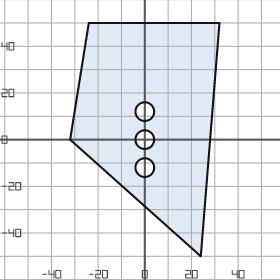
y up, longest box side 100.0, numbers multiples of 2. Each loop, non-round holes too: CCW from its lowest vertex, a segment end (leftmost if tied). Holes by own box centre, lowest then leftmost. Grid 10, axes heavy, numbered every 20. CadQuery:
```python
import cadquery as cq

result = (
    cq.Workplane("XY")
    .moveTo(24.0, -50.0)
    .lineTo(32.0, 50.0)
    .lineTo(-24.0, 50.0)
    .lineTo(-32.0, 0.0)
    .close()
    .moveTo(0.0, -12.0)
    .circle(4.0)
    .moveTo(0.0, 0.0)
    .circle(4.0)
    .moveTo(0.0, 12.0)
    .circle(4.0)
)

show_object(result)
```